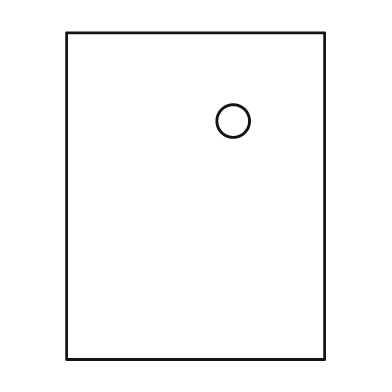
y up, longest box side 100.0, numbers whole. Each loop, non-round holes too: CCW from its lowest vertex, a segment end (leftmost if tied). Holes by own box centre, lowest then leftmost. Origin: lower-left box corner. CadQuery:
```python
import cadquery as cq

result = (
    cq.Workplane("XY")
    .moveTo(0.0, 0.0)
    .lineTo(79.0, 0.0)
    .lineTo(79.0, 100.0)
    .lineTo(0.0, 100.0)
    .close()
    .moveTo(51.0, 73.0)
    .circle(5.0)
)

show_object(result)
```